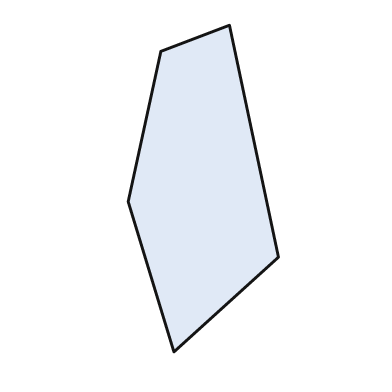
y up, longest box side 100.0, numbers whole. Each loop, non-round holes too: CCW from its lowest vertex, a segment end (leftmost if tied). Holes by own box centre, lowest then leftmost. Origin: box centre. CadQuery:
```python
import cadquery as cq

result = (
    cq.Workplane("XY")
    .moveTo(-9.0, -50.0)
    .lineTo(23.0, -21.0)
    .lineTo(8.0, 50.0)
    .lineTo(-13.0, 42.0)
    .lineTo(-23.0, -4.0)
    .close()
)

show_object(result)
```